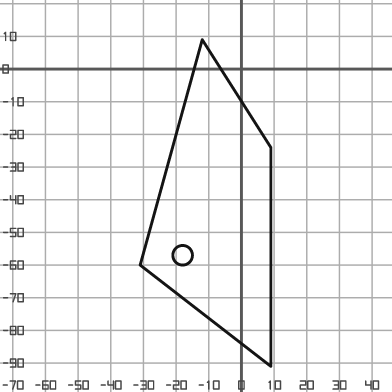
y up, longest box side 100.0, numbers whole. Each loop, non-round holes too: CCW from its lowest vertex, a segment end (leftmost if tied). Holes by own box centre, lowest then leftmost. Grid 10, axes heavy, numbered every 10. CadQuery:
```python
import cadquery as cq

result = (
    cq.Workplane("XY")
    .moveTo(9.0, -91.0)
    .lineTo(9.0, -24.0)
    .lineTo(-12.0, 9.0)
    .lineTo(-31.0, -60.0)
    .close()
    .moveTo(-18.0, -57.0)
    .circle(3.0)
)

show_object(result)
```